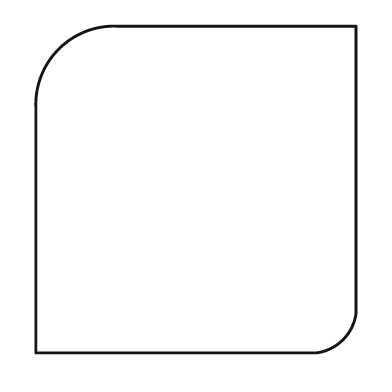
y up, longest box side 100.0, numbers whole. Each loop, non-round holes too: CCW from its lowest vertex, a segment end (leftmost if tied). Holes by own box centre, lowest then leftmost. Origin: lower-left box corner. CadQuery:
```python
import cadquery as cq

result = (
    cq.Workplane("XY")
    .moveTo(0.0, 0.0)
    .lineTo(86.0, 0.0)
    .threePointArc((94.0, 4.0), (98.0, 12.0))
    .lineTo(98.0, 100.0)
    .lineTo(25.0, 100.0)
    .threePointArc((7.0, 93.0), (0.0, 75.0))
    .close()
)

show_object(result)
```